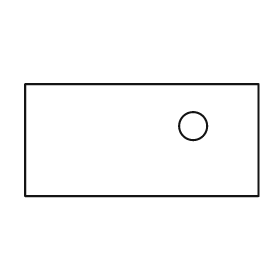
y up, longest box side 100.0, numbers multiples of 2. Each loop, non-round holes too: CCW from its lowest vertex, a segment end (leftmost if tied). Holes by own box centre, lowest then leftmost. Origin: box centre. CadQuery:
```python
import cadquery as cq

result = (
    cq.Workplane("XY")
    .moveTo(-50.0, -24.0)
    .lineTo(50.0, -24.0)
    .lineTo(50.0, 24.0)
    .lineTo(-50.0, 24.0)
    .close()
    .moveTo(22.0, 6.0)
    .circle(6.0)
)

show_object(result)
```